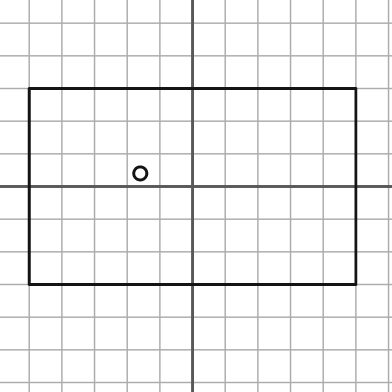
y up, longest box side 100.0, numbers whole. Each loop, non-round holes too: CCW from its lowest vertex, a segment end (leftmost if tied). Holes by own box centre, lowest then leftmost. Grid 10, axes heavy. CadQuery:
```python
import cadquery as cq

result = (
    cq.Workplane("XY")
    .moveTo(-50.0, -30.0)
    .lineTo(50.0, -30.0)
    .lineTo(50.0, 30.0)
    .lineTo(-50.0, 30.0)
    .close()
    .moveTo(-16.0, 4.0)
    .circle(2.0)
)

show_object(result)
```